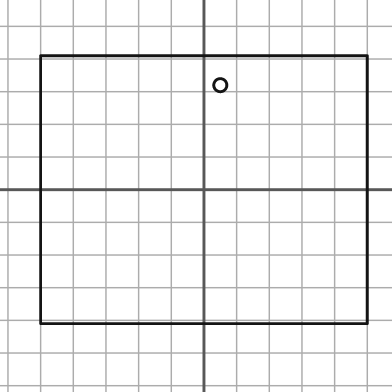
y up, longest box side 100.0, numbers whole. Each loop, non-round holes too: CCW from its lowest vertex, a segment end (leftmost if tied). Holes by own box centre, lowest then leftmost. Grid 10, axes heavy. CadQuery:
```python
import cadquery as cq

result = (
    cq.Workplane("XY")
    .moveTo(-50.0, -41.0)
    .lineTo(50.0, -41.0)
    .lineTo(50.0, 41.0)
    .lineTo(-50.0, 41.0)
    .close()
    .moveTo(5.0, 32.0)
    .circle(2.0)
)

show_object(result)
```